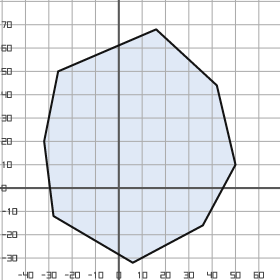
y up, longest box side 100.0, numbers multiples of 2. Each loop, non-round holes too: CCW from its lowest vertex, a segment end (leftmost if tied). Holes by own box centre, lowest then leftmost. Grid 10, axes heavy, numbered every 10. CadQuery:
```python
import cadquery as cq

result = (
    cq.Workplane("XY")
    .moveTo(6.0, -32.0)
    .lineTo(36.0, -16.0)
    .lineTo(50.0, 10.0)
    .lineTo(42.0, 44.0)
    .lineTo(16.0, 68.0)
    .lineTo(-26.0, 50.0)
    .lineTo(-32.0, 20.0)
    .lineTo(-28.0, -12.0)
    .close()
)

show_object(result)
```